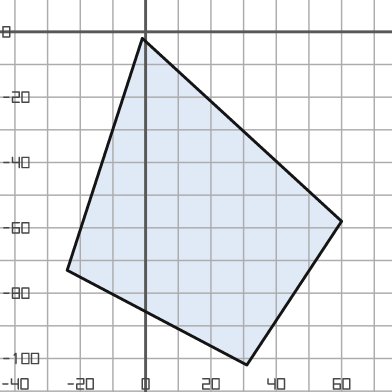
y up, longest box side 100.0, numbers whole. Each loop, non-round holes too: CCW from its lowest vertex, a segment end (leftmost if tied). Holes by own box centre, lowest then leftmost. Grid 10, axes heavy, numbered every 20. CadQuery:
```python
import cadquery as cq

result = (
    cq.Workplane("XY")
    .moveTo(31.0, -102.0)
    .lineTo(60.0, -58.0)
    .lineTo(-1.0, -2.0)
    .lineTo(-24.0, -73.0)
    .close()
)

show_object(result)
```